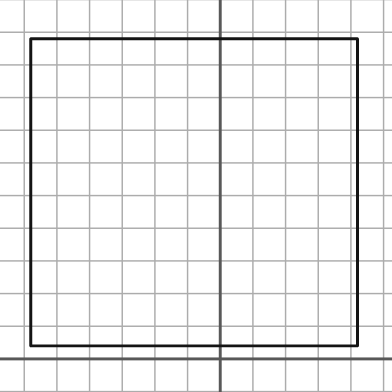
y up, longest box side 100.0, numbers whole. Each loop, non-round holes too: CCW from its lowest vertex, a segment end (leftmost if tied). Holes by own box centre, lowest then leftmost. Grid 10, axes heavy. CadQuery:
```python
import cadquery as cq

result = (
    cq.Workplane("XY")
    .moveTo(-58.0, 4.0)
    .lineTo(42.0, 4.0)
    .lineTo(42.0, 98.0)
    .lineTo(-58.0, 98.0)
    .close()
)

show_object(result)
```